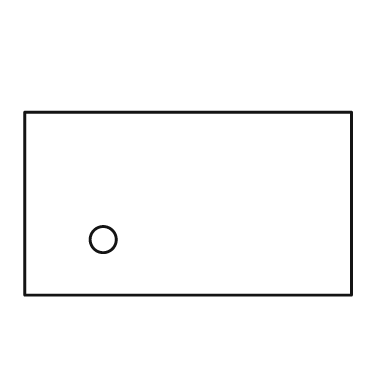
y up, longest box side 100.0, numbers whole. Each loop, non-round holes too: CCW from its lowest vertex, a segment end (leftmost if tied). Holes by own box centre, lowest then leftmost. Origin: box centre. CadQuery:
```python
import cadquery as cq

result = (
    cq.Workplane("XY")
    .moveTo(-50.0, -28.0)
    .lineTo(50.0, -28.0)
    .lineTo(50.0, 28.0)
    .lineTo(-50.0, 28.0)
    .close()
    .moveTo(-26.0, -11.0)
    .circle(4.0)
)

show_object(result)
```